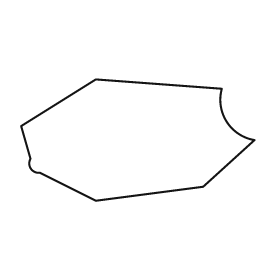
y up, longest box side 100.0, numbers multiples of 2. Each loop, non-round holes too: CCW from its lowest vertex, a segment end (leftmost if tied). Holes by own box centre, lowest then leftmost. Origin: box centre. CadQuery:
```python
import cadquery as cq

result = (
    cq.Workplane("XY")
    .moveTo(-18.0, -26.0)
    .lineTo(28.0, -20.0)
    .lineTo(50.0, 0.0)
    .threePointArc((38.0, 8.0), (36.0, 22.0))
    .lineTo(-18.0, 26.0)
    .lineTo(-50.0, 6.0)
    .lineTo(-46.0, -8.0)
    .threePointArc((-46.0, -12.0), (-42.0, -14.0))
    .close()
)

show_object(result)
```